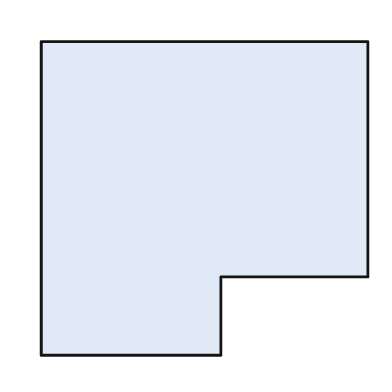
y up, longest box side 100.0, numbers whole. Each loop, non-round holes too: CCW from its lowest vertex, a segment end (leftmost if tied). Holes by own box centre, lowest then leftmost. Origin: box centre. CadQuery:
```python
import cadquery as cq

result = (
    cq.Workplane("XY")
    .moveTo(-50.0, -48.0)
    .lineTo(5.0, -48.0)
    .lineTo(5.0, -24.0)
    .lineTo(50.0, -24.0)
    .lineTo(50.0, 48.0)
    .lineTo(-50.0, 48.0)
    .close()
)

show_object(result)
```